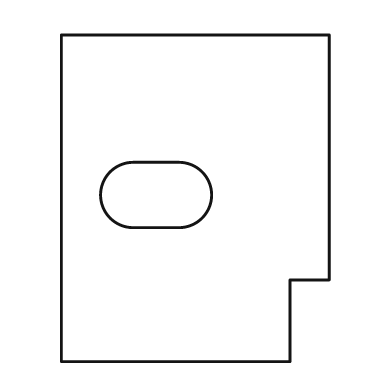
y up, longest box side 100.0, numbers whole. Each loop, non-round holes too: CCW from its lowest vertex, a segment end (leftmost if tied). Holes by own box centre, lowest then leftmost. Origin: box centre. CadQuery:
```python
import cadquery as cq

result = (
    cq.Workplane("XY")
    .moveTo(-41.0, -50.0)
    .lineTo(29.0, -50.0)
    .lineTo(29.0, -25.0)
    .lineTo(41.0, -25.0)
    .lineTo(41.0, 50.0)
    .lineTo(-41.0, 50.0)
    .close()
    .moveTo(-19.0, -9.0)
    .lineTo(-5.0, -9.0)
    .threePointArc((5.0, 1.0), (-5.0, 11.0))
    .lineTo(-19.0, 11.0)
    .threePointArc((-29.0, 1.0), (-19.0, -9.0))
    .close()
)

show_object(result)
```